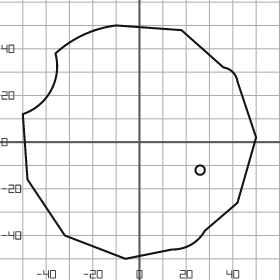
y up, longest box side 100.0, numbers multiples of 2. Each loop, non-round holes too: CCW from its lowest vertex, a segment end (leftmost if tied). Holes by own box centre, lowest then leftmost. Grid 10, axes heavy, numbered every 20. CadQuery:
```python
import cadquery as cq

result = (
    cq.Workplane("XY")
    .moveTo(-6.0, -50.0)
    .lineTo(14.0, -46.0)
    .threePointArc((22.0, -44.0), (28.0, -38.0))
    .lineTo(42.0, -26.0)
    .lineTo(50.0, 2.0)
    .lineTo(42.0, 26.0)
    .threePointArc((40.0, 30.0), (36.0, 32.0))
    .lineTo(18.0, 48.0)
    .lineTo(-10.0, 50.0)
    .threePointArc((-24.0, 46.0), (-36.0, 38.0))
    .threePointArc((-38.0, 22.0), (-50.0, 12.0))
    .lineTo(-48.0, -16.0)
    .lineTo(-32.0, -40.0)
    .close()
    .moveTo(26.0, -12.0)
    .circle(2.0)
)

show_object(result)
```